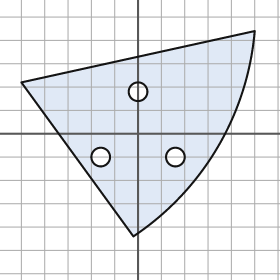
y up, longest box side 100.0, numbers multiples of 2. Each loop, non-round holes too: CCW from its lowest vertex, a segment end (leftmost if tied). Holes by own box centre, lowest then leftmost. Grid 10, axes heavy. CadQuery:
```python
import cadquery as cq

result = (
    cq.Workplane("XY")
    .moveTo(-2.0, -44.0)
    .threePointArc((34.0, -6.0), (50.0, 44.0))
    .lineTo(-50.0, 22.0)
    .close()
    .moveTo(-16.0, -10.0)
    .circle(4.0)
    .moveTo(16.0, -10.0)
    .circle(4.0)
    .moveTo(0.0, 18.0)
    .circle(4.0)
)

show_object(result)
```